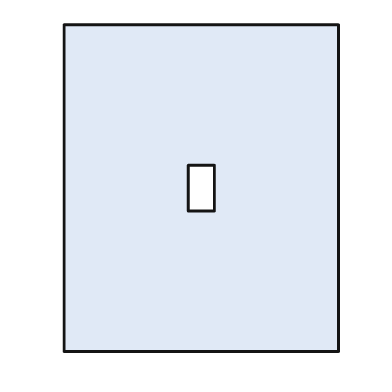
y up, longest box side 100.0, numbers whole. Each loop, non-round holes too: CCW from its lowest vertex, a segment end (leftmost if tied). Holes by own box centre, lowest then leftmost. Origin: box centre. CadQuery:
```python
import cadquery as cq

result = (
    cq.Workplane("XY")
    .moveTo(-42.0, -50.0)
    .lineTo(42.0, -50.0)
    .lineTo(42.0, 50.0)
    .lineTo(-42.0, 50.0)
    .close()
    .moveTo(-4.0, -7.0)
    .lineTo(4.0, -7.0)
    .lineTo(4.0, 7.0)
    .lineTo(-4.0, 7.0)
    .close()
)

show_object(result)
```